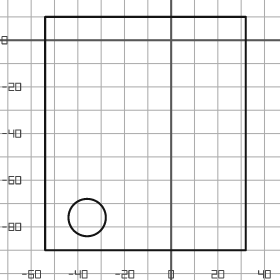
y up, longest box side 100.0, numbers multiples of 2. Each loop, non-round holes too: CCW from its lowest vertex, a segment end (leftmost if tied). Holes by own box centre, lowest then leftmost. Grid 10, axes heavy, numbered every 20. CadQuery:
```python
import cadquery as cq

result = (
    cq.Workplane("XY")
    .moveTo(-54.0, -90.0)
    .lineTo(32.0, -90.0)
    .lineTo(32.0, 10.0)
    .lineTo(-54.0, 10.0)
    .close()
    .moveTo(-36.0, -76.0)
    .circle(8.0)
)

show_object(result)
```